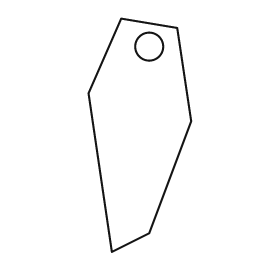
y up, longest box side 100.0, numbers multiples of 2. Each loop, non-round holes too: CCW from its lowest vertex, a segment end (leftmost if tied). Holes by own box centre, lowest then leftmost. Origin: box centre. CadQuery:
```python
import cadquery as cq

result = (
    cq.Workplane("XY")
    .moveTo(-12.0, -50.0)
    .lineTo(4.0, -42.0)
    .lineTo(22.0, 6.0)
    .lineTo(16.0, 46.0)
    .lineTo(-8.0, 50.0)
    .lineTo(-22.0, 18.0)
    .close()
    .moveTo(4.0, 38.0)
    .circle(6.0)
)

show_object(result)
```